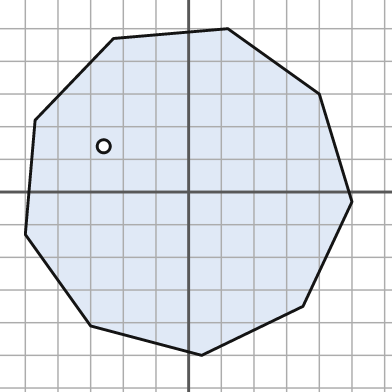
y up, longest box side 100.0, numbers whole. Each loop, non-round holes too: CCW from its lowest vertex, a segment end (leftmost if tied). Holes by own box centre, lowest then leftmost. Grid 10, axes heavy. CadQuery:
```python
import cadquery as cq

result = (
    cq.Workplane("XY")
    .moveTo(4.0, -50.0)
    .lineTo(35.0, -35.0)
    .lineTo(50.0, -3.0)
    .lineTo(40.0, 30.0)
    .lineTo(12.0, 50.0)
    .lineTo(-23.0, 47.0)
    .lineTo(-47.0, 22.0)
    .lineTo(-50.0, -13.0)
    .lineTo(-30.0, -41.0)
    .close()
    .moveTo(-26.0, 14.0)
    .circle(2.0)
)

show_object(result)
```